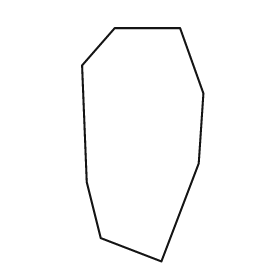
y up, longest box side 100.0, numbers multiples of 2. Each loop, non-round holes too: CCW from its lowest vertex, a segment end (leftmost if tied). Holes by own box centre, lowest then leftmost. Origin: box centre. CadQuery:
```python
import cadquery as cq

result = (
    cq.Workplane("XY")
    .moveTo(8.0, -50.0)
    .lineTo(24.0, -8.0)
    .lineTo(26.0, 22.0)
    .lineTo(16.0, 50.0)
    .lineTo(-12.0, 50.0)
    .lineTo(-26.0, 34.0)
    .lineTo(-24.0, -16.0)
    .lineTo(-18.0, -40.0)
    .close()
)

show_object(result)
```